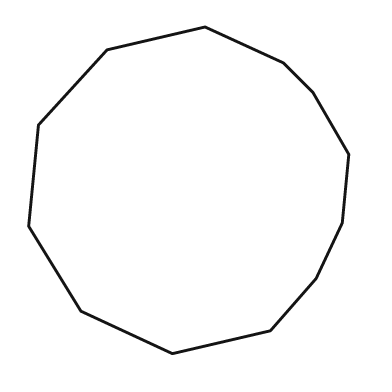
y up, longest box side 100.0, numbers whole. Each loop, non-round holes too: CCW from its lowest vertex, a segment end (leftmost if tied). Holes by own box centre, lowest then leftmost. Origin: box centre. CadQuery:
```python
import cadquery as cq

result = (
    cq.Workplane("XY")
    .moveTo(-5.0, -50.0)
    .lineTo(25.0, -43.0)
    .lineTo(39.0, -27.0)
    .lineTo(47.0, -10.0)
    .lineTo(49.0, 11.0)
    .lineTo(38.0, 30.0)
    .lineTo(29.0, 39.0)
    .lineTo(5.0, 50.0)
    .lineTo(-25.0, 43.0)
    .lineTo(-46.0, 20.0)
    .lineTo(-49.0, -11.0)
    .lineTo(-33.0, -37.0)
    .close()
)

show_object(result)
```